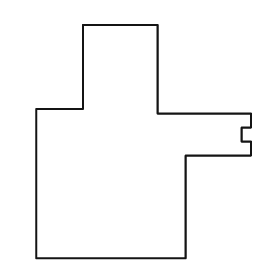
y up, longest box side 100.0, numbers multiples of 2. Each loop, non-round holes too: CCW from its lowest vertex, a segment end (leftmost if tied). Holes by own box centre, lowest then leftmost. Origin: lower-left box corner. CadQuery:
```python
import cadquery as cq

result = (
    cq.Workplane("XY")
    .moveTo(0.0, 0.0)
    .lineTo(64.0, 0.0)
    .lineTo(64.0, 44.0)
    .lineTo(92.0, 44.0)
    .lineTo(92.0, 50.0)
    .lineTo(88.0, 50.0)
    .lineTo(88.0, 56.0)
    .lineTo(92.0, 56.0)
    .lineTo(92.0, 62.0)
    .lineTo(52.0, 62.0)
    .lineTo(52.0, 100.0)
    .lineTo(20.0, 100.0)
    .lineTo(20.0, 64.0)
    .lineTo(0.0, 64.0)
    .close()
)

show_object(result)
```